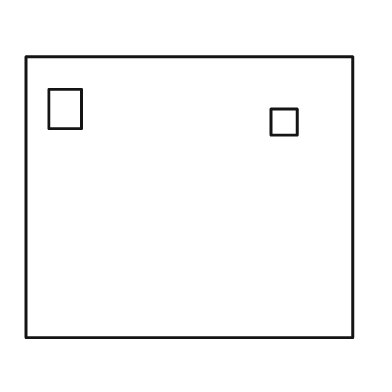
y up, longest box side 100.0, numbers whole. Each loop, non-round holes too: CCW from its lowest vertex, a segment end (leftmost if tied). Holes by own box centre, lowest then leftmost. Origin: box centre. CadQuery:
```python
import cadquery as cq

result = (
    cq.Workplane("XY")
    .moveTo(-50.0, -43.0)
    .lineTo(50.0, -43.0)
    .lineTo(50.0, 43.0)
    .lineTo(-50.0, 43.0)
    .close()
    .moveTo(25.0, 19.0)
    .lineTo(33.0, 19.0)
    .lineTo(33.0, 27.0)
    .lineTo(25.0, 27.0)
    .close()
    .moveTo(-43.0, 21.0)
    .lineTo(-33.0, 21.0)
    .lineTo(-33.0, 33.0)
    .lineTo(-43.0, 33.0)
    .close()
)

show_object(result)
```